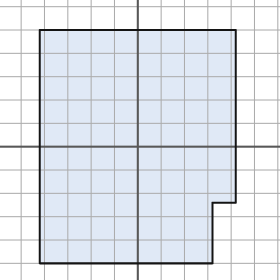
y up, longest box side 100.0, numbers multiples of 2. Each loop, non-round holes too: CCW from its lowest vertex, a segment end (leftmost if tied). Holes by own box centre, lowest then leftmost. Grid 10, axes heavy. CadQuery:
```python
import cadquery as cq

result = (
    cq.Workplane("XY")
    .moveTo(-42.0, -50.0)
    .lineTo(32.0, -50.0)
    .lineTo(32.0, -24.0)
    .lineTo(42.0, -24.0)
    .lineTo(42.0, 50.0)
    .lineTo(-42.0, 50.0)
    .close()
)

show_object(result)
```